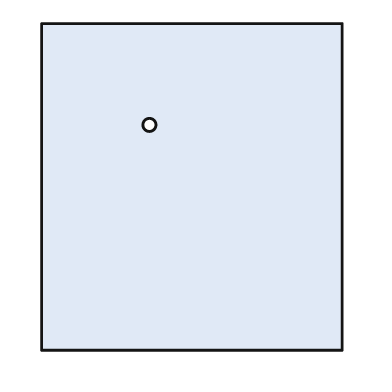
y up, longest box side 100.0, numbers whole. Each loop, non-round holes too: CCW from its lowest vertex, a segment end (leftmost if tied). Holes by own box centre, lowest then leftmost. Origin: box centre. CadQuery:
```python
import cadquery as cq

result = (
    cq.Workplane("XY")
    .moveTo(-46.0, -50.0)
    .lineTo(46.0, -50.0)
    .lineTo(46.0, 50.0)
    .lineTo(-46.0, 50.0)
    .close()
    .moveTo(-13.0, 19.0)
    .circle(2.0)
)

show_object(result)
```